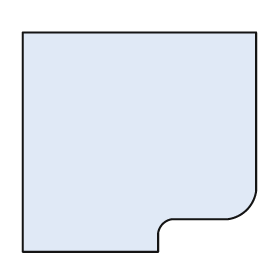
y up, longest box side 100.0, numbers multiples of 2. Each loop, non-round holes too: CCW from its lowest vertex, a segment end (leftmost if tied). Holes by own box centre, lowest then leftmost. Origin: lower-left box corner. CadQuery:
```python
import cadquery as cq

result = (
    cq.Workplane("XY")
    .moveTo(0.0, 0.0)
    .lineTo(58.0, 0.0)
    .lineTo(58.0, 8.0)
    .threePointArc((60.0, 12.0), (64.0, 14.0))
    .lineTo(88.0, 14.0)
    .threePointArc((96.0, 18.0), (100.0, 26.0))
    .lineTo(100.0, 94.0)
    .lineTo(0.0, 94.0)
    .close()
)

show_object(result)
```